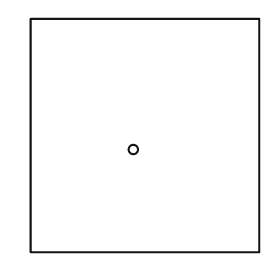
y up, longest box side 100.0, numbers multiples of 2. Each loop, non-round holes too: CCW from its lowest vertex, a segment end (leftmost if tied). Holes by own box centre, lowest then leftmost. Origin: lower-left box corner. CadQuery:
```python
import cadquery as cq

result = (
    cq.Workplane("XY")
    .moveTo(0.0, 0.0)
    .lineTo(98.0, 0.0)
    .lineTo(98.0, 100.0)
    .lineTo(0.0, 100.0)
    .close()
    .moveTo(44.0, 44.0)
    .circle(2.0)
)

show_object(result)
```